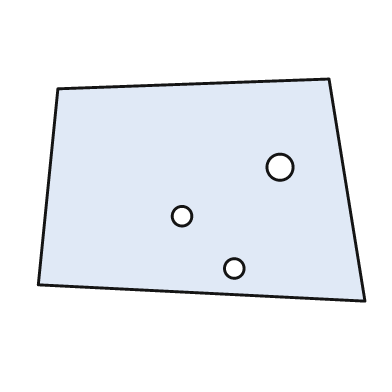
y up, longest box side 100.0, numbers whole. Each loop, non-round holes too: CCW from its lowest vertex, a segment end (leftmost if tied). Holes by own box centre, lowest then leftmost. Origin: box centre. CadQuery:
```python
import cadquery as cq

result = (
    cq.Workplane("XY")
    .moveTo(50.0, -34.0)
    .lineTo(39.0, 34.0)
    .lineTo(-44.0, 31.0)
    .lineTo(-50.0, -29.0)
    .close()
    .moveTo(10.0, -24.0)
    .circle(3.0)
    .moveTo(-6.0, -8.0)
    .circle(3.0)
    .moveTo(24.0, 7.0)
    .circle(4.0)
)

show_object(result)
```